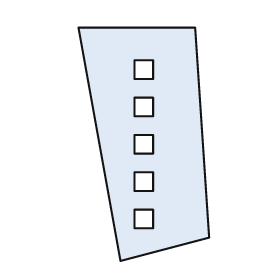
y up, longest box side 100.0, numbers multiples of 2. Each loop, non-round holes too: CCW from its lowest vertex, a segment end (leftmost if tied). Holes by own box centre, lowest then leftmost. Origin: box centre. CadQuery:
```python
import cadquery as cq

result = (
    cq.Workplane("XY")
    .moveTo(-10.0, -50.0)
    .lineTo(28.0, -40.0)
    .lineTo(22.0, 50.0)
    .lineTo(-28.0, 50.0)
    .close()
    .moveTo(-4.0, -36.0)
    .lineTo(4.0, -36.0)
    .lineTo(4.0, -28.0)
    .lineTo(-4.0, -28.0)
    .close()
    .moveTo(-4.0, -20.0)
    .lineTo(4.0, -20.0)
    .lineTo(4.0, -12.0)
    .lineTo(-4.0, -12.0)
    .close()
    .moveTo(-4.0, -4.0)
    .lineTo(4.0, -4.0)
    .lineTo(4.0, 4.0)
    .lineTo(-4.0, 4.0)
    .close()
    .moveTo(-4.0, 12.0)
    .lineTo(4.0, 12.0)
    .lineTo(4.0, 20.0)
    .lineTo(-4.0, 20.0)
    .close()
    .moveTo(-4.0, 28.0)
    .lineTo(4.0, 28.0)
    .lineTo(4.0, 36.0)
    .lineTo(-4.0, 36.0)
    .close()
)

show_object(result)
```